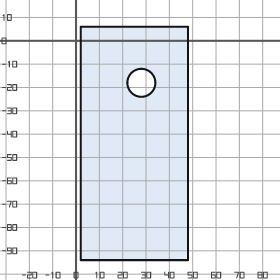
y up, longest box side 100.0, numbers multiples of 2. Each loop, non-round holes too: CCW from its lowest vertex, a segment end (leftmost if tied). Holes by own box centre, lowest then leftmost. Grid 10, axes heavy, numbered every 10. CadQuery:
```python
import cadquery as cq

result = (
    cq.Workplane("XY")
    .moveTo(2.0, -94.0)
    .lineTo(48.0, -94.0)
    .lineTo(48.0, 6.0)
    .lineTo(2.0, 6.0)
    .close()
    .moveTo(28.0, -18.0)
    .circle(6.0)
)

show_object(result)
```